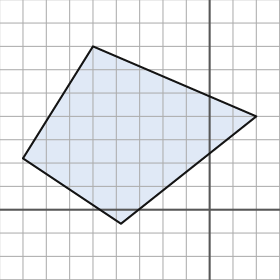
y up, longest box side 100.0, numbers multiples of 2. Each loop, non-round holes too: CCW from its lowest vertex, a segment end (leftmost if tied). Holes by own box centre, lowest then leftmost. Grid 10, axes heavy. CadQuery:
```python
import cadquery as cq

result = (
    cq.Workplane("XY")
    .moveTo(-38.0, -6.0)
    .lineTo(20.0, 40.0)
    .lineTo(-50.0, 70.0)
    .lineTo(-80.0, 22.0)
    .close()
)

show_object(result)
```